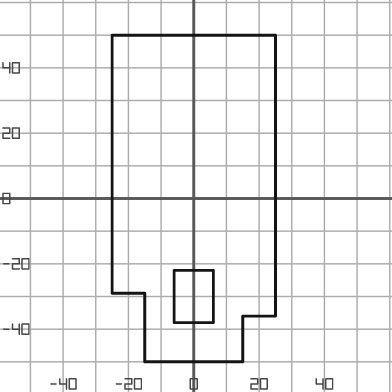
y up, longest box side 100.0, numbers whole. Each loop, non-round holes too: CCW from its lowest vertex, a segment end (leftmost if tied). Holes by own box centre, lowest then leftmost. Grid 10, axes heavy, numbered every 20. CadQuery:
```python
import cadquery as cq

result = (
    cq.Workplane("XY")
    .moveTo(-15.0, -50.0)
    .lineTo(15.0, -50.0)
    .lineTo(15.0, -36.0)
    .lineTo(25.0, -36.0)
    .lineTo(25.0, 50.0)
    .lineTo(-25.0, 50.0)
    .lineTo(-25.0, -29.0)
    .lineTo(-15.0, -29.0)
    .close()
    .moveTo(-6.0, -38.0)
    .lineTo(6.0, -38.0)
    .lineTo(6.0, -22.0)
    .lineTo(-6.0, -22.0)
    .close()
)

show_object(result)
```